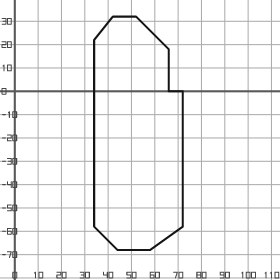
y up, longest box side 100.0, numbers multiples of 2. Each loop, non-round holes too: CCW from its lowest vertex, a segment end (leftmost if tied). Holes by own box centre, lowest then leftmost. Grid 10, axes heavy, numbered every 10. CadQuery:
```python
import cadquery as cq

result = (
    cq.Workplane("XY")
    .moveTo(44.0, -68.0)
    .lineTo(58.0, -68.0)
    .lineTo(72.0, -58.0)
    .lineTo(72.0, 0.0)
    .lineTo(66.0, 0.0)
    .lineTo(66.0, 18.0)
    .lineTo(52.0, 32.0)
    .lineTo(42.0, 32.0)
    .lineTo(34.0, 22.0)
    .lineTo(34.0, -58.0)
    .close()
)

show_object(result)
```